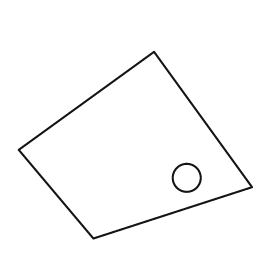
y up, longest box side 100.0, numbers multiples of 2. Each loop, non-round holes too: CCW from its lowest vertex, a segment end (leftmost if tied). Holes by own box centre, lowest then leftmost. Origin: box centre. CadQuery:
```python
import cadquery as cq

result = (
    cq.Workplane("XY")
    .moveTo(-18.0, -40.0)
    .lineTo(50.0, -18.0)
    .lineTo(8.0, 40.0)
    .lineTo(-50.0, -2.0)
    .close()
    .moveTo(22.0, -14.0)
    .circle(6.0)
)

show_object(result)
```